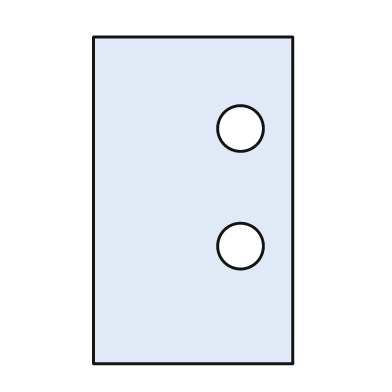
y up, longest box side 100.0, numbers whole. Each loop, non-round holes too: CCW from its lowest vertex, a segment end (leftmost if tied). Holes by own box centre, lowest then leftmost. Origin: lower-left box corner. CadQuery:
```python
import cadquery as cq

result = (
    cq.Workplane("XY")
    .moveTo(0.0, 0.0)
    .lineTo(61.0, 0.0)
    .lineTo(61.0, 100.0)
    .lineTo(0.0, 100.0)
    .close()
    .moveTo(45.0, 36.0)
    .circle(7.0)
    .moveTo(45.0, 72.0)
    .circle(7.0)
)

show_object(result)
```